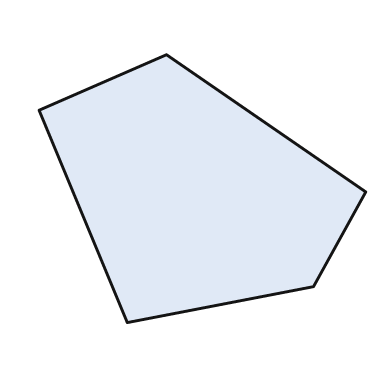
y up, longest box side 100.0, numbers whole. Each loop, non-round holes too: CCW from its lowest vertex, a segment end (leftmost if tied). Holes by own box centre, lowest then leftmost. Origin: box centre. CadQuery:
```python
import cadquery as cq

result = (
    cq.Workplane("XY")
    .moveTo(-23.0, -41.0)
    .lineTo(34.0, -30.0)
    .lineTo(50.0, -1.0)
    .lineTo(-11.0, 41.0)
    .lineTo(-50.0, 24.0)
    .close()
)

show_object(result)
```